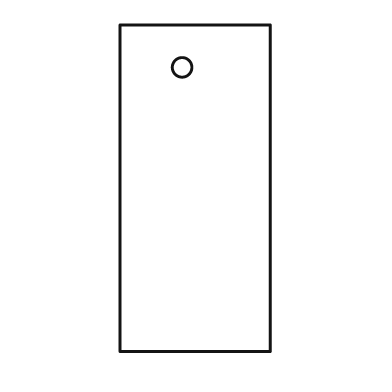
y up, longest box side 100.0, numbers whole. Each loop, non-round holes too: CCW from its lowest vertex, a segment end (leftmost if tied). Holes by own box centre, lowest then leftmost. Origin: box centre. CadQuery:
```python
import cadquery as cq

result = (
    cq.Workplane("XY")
    .moveTo(-23.0, -50.0)
    .lineTo(23.0, -50.0)
    .lineTo(23.0, 50.0)
    .lineTo(-23.0, 50.0)
    .close()
    .moveTo(-4.0, 37.0)
    .circle(3.0)
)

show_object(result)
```